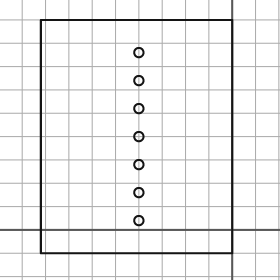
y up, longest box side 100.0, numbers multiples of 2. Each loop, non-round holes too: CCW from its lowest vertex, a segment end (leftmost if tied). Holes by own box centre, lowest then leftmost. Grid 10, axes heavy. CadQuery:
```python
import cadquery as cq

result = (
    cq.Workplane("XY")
    .moveTo(-82.0, -10.0)
    .lineTo(0.0, -10.0)
    .lineTo(0.0, 90.0)
    .lineTo(-82.0, 90.0)
    .close()
    .moveTo(-40.0, 4.0)
    .circle(2.0)
    .moveTo(-40.0, 16.0)
    .circle(2.0)
    .moveTo(-40.0, 28.0)
    .circle(2.0)
    .moveTo(-40.0, 40.0)
    .circle(2.0)
    .moveTo(-40.0, 52.0)
    .circle(2.0)
    .moveTo(-40.0, 64.0)
    .circle(2.0)
    .moveTo(-40.0, 76.0)
    .circle(2.0)
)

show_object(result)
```